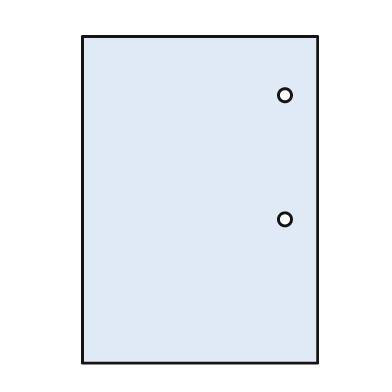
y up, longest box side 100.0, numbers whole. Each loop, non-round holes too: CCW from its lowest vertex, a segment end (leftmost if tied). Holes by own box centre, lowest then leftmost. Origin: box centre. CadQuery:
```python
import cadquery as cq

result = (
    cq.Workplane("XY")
    .moveTo(-36.0, -50.0)
    .lineTo(36.0, -50.0)
    .lineTo(36.0, 50.0)
    .lineTo(-36.0, 50.0)
    .close()
    .moveTo(26.0, -6.0)
    .circle(2.0)
    .moveTo(26.0, 32.0)
    .circle(2.0)
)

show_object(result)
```